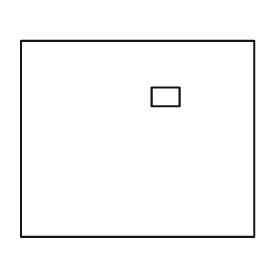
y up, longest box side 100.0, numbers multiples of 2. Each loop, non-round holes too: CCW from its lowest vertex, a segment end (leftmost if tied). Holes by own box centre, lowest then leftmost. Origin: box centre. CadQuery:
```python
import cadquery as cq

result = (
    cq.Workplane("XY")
    .moveTo(-50.0, -42.0)
    .lineTo(50.0, -42.0)
    .lineTo(50.0, 42.0)
    .lineTo(-50.0, 42.0)
    .close()
    .moveTo(6.0, 14.0)
    .lineTo(18.0, 14.0)
    .lineTo(18.0, 22.0)
    .lineTo(6.0, 22.0)
    .close()
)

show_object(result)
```